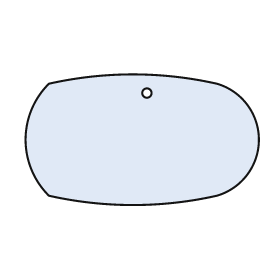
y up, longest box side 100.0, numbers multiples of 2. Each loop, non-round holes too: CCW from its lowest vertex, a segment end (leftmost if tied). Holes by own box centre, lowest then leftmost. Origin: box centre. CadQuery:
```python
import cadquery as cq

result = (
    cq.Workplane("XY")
    .moveTo(-40.0, -24.0)
    .threePointArc((-4.0, -28.0), (32.0, -24.0))
    .threePointArc((50.0, 0.0), (32.0, 24.0))
    .threePointArc((-4.0, 28.0), (-40.0, 24.0))
    .threePointArc((-50.0, 0.0), (-40.0, -24.0))
    .close()
    .moveTo(2.0, 20.0)
    .circle(2.0)
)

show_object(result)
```